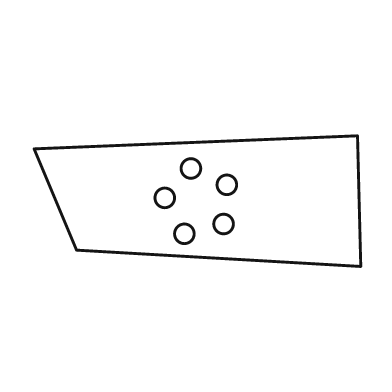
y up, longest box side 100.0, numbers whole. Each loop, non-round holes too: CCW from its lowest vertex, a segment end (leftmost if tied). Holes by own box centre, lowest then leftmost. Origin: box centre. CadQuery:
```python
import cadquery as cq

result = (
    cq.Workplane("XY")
    .moveTo(50.0, -20.0)
    .lineTo(49.0, 20.0)
    .lineTo(-50.0, 16.0)
    .lineTo(-37.0, -15.0)
    .close()
    .moveTo(-4.0, -10.0)
    .circle(3.0)
    .moveTo(8.0, -7.0)
    .circle(3.0)
    .moveTo(-10.0, 1.0)
    .circle(3.0)
    .moveTo(9.0, 5.0)
    .circle(3.0)
    .moveTo(-2.0, 10.0)
    .circle(3.0)
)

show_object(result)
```